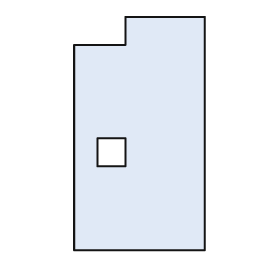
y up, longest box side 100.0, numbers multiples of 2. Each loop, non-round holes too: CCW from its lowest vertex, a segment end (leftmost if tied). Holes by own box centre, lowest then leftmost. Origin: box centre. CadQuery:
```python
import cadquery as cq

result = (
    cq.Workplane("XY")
    .moveTo(-28.0, -50.0)
    .lineTo(28.0, -50.0)
    .lineTo(28.0, 50.0)
    .lineTo(-6.0, 50.0)
    .lineTo(-6.0, 38.0)
    .lineTo(-28.0, 38.0)
    .close()
    .moveTo(-18.0, -14.0)
    .lineTo(-6.0, -14.0)
    .lineTo(-6.0, -2.0)
    .lineTo(-18.0, -2.0)
    .close()
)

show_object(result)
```